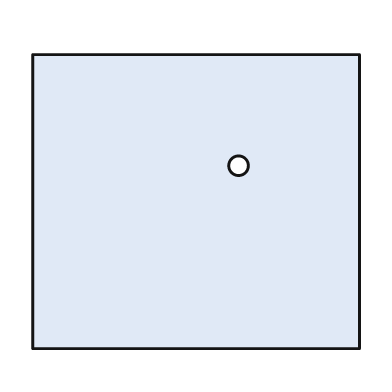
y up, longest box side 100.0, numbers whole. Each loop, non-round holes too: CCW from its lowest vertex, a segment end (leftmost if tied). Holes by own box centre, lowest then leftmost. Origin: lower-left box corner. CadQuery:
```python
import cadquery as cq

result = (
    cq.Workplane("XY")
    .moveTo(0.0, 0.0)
    .lineTo(100.0, 0.0)
    .lineTo(100.0, 90.0)
    .lineTo(0.0, 90.0)
    .close()
    .moveTo(63.0, 56.0)
    .circle(3.0)
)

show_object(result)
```